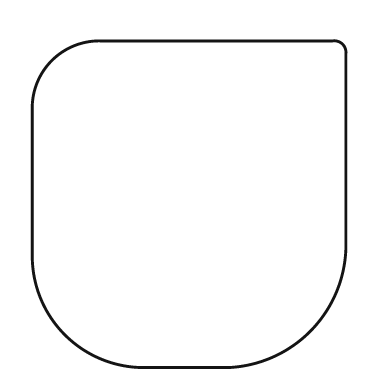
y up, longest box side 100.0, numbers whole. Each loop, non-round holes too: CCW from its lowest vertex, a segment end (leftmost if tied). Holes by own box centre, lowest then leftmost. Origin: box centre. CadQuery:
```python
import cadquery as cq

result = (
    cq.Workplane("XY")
    .moveTo(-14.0, -50.0)
    .lineTo(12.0, -50.0)
    .threePointArc((37.0, -39.0), (48.0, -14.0))
    .lineTo(48.0, 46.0)
    .threePointArc((47.0, 49.0), (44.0, 50.0))
    .lineTo(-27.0, 50.0)
    .threePointArc((-42.0, 44.0), (-48.0, 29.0))
    .lineTo(-48.0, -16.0)
    .threePointArc((-38.0, -40.0), (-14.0, -50.0))
    .close()
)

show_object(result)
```